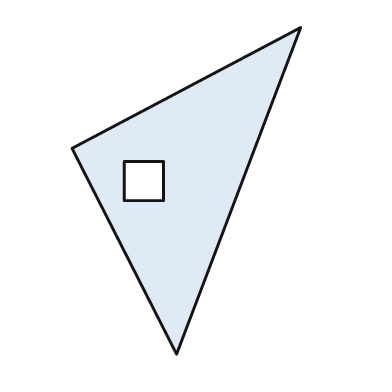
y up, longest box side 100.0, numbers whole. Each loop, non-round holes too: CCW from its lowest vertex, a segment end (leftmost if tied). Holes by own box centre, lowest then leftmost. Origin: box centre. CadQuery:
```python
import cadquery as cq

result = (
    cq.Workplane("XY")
    .moveTo(-3.0, -50.0)
    .lineTo(35.0, 50.0)
    .lineTo(-35.0, 13.0)
    .close()
    .moveTo(-19.0, -3.0)
    .lineTo(-7.0, -3.0)
    .lineTo(-7.0, 9.0)
    .lineTo(-19.0, 9.0)
    .close()
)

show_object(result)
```